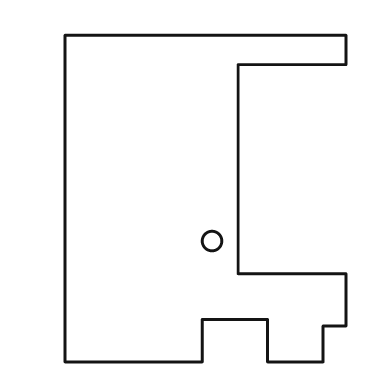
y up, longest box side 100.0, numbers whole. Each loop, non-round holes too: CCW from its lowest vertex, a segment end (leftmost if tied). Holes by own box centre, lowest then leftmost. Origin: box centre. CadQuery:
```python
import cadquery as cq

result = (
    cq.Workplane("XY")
    .moveTo(-43.0, -50.0)
    .lineTo(-1.0, -50.0)
    .lineTo(-1.0, -37.0)
    .lineTo(19.0, -37.0)
    .lineTo(19.0, -50.0)
    .lineTo(36.0, -50.0)
    .lineTo(36.0, -39.0)
    .lineTo(43.0, -39.0)
    .lineTo(43.0, -23.0)
    .lineTo(10.0, -23.0)
    .lineTo(10.0, 41.0)
    .lineTo(43.0, 41.0)
    .lineTo(43.0, 50.0)
    .lineTo(-43.0, 50.0)
    .close()
    .moveTo(2.0, -13.0)
    .circle(3.0)
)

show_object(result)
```